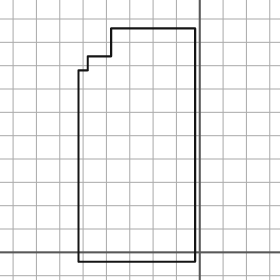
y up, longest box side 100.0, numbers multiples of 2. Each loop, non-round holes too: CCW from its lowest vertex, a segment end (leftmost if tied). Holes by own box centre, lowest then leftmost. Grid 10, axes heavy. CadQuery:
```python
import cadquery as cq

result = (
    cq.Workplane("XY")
    .moveTo(-52.0, -4.0)
    .lineTo(-2.0, -4.0)
    .lineTo(-2.0, 96.0)
    .lineTo(-38.0, 96.0)
    .lineTo(-38.0, 84.0)
    .lineTo(-48.0, 84.0)
    .lineTo(-48.0, 78.0)
    .lineTo(-52.0, 78.0)
    .close()
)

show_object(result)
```